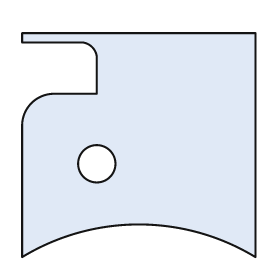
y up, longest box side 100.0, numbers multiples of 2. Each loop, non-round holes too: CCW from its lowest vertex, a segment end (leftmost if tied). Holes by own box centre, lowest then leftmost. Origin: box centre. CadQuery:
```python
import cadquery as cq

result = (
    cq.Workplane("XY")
    .moveTo(-50.0, -48.0)
    .threePointArc((0.0, -34.0), (50.0, -48.0))
    .lineTo(50.0, 48.0)
    .lineTo(-50.0, 48.0)
    .lineTo(-50.0, 44.0)
    .lineTo(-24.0, 44.0)
    .threePointArc((-20.0, 42.0), (-18.0, 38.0))
    .lineTo(-18.0, 22.0)
    .lineTo(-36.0, 22.0)
    .threePointArc((-46.0, 18.0), (-50.0, 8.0))
    .close()
    .moveTo(-18.0, -8.0)
    .circle(8.0)
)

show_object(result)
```